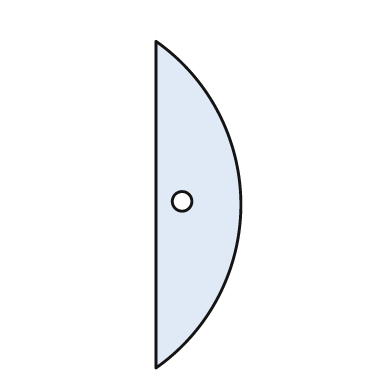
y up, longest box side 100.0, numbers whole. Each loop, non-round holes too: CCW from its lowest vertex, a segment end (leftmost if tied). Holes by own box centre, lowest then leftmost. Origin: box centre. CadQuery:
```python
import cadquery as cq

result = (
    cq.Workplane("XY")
    .moveTo(-13.0, -50.0)
    .threePointArc((13.0, 0.0), (-13.0, 50.0))
    .close()
    .moveTo(-5.0, 1.0)
    .circle(3.0)
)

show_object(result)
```